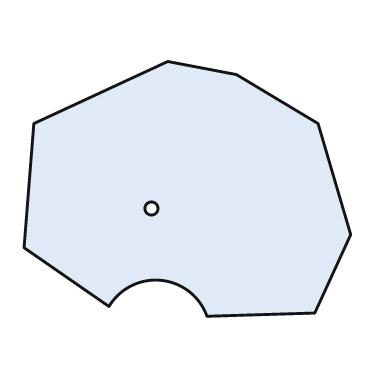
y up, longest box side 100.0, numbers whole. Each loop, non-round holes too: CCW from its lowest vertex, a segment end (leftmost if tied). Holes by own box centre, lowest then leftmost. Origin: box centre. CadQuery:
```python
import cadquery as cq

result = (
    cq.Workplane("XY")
    .moveTo(6.0, -39.0)
    .lineTo(39.0, -38.0)
    .lineTo(50.0, -14.0)
    .lineTo(40.0, 20.0)
    .lineTo(15.0, 35.0)
    .lineTo(-6.0, 39.0)
    .lineTo(-47.0, 20.0)
    .lineTo(-50.0, -18.0)
    .lineTo(-24.0, -36.0)
    .threePointArc((-8.0, -28.0), (6.0, -39.0))
    .close()
    .moveTo(-11.0, -6.0)
    .circle(2.0)
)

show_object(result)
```